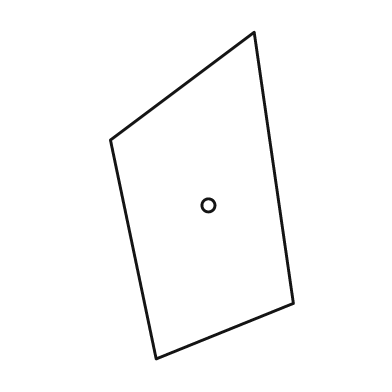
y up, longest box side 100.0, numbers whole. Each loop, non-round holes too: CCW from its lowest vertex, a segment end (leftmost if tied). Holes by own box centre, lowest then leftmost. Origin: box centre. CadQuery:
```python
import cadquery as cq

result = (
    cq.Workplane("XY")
    .moveTo(-14.0, -50.0)
    .lineTo(28.0, -33.0)
    .lineTo(16.0, 50.0)
    .lineTo(-28.0, 17.0)
    .close()
    .moveTo(2.0, -3.0)
    .circle(2.0)
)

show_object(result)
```